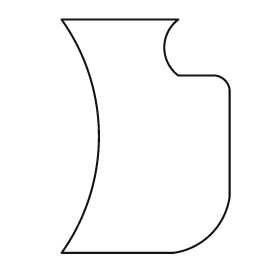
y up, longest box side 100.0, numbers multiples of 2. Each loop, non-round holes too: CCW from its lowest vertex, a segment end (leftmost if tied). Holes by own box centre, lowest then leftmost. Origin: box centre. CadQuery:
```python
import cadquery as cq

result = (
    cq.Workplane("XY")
    .moveTo(-36.0, -50.0)
    .lineTo(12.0, -50.0)
    .threePointArc((28.0, -42.0), (36.0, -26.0))
    .lineTo(36.0, 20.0)
    .threePointArc((34.0, 24.0), (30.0, 26.0))
    .lineTo(14.0, 26.0)
    .threePointArc((8.0, 38.0), (14.0, 50.0))
    .lineTo(-36.0, 50.0)
    .threePointArc((-20.0, 0.0), (-36.0, -50.0))
    .close()
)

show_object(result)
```